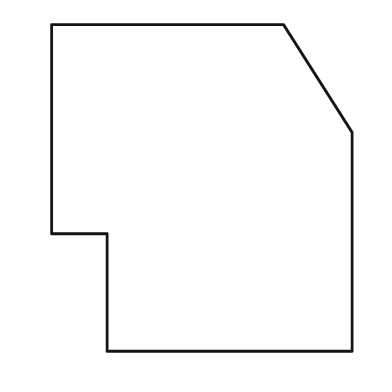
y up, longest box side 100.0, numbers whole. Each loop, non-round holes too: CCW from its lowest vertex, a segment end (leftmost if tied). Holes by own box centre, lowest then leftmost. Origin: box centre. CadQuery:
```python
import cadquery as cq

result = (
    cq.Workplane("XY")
    .moveTo(-29.0, -50.0)
    .lineTo(46.0, -50.0)
    .lineTo(46.0, 17.0)
    .lineTo(25.0, 50.0)
    .lineTo(-46.0, 50.0)
    .lineTo(-46.0, -14.0)
    .lineTo(-29.0, -14.0)
    .close()
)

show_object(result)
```